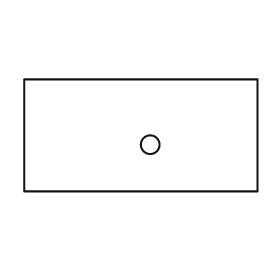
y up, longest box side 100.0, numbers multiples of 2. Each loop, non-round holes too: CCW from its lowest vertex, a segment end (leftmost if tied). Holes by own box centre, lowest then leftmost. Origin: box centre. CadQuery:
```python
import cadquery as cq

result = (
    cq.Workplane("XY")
    .moveTo(-50.0, -24.0)
    .lineTo(50.0, -24.0)
    .lineTo(50.0, 24.0)
    .lineTo(-50.0, 24.0)
    .close()
    .moveTo(4.0, -4.0)
    .circle(4.0)
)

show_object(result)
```